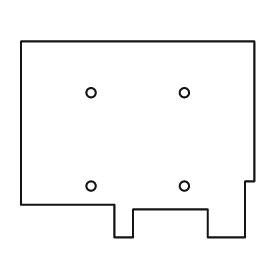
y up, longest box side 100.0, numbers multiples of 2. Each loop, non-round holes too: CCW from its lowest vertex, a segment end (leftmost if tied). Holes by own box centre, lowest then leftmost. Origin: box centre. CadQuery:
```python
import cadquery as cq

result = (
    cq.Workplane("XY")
    .moveTo(-10.0, -42.0)
    .lineTo(-2.0, -42.0)
    .lineTo(-2.0, -30.0)
    .lineTo(30.0, -30.0)
    .lineTo(30.0, -42.0)
    .lineTo(46.0, -42.0)
    .lineTo(46.0, -18.0)
    .lineTo(50.0, -18.0)
    .lineTo(50.0, 42.0)
    .lineTo(-50.0, 42.0)
    .lineTo(-50.0, -28.0)
    .lineTo(-10.0, -28.0)
    .close()
    .moveTo(-20.0, -20.0)
    .circle(2.0)
    .moveTo(20.0, -20.0)
    .circle(2.0)
    .moveTo(-20.0, 20.0)
    .circle(2.0)
    .moveTo(20.0, 20.0)
    .circle(2.0)
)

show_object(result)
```